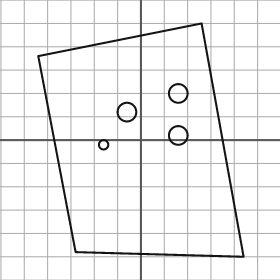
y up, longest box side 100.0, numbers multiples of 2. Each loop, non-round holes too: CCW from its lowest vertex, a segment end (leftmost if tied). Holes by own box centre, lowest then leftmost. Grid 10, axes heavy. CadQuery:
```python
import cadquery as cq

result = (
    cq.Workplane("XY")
    .moveTo(44.0, -50.0)
    .lineTo(26.0, 50.0)
    .lineTo(-44.0, 36.0)
    .lineTo(-28.0, -48.0)
    .close()
    .moveTo(-16.0, -2.0)
    .circle(2.0)
    .moveTo(16.0, 2.0)
    .circle(4.0)
    .moveTo(-6.0, 12.0)
    .circle(4.0)
    .moveTo(16.0, 20.0)
    .circle(4.0)
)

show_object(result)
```